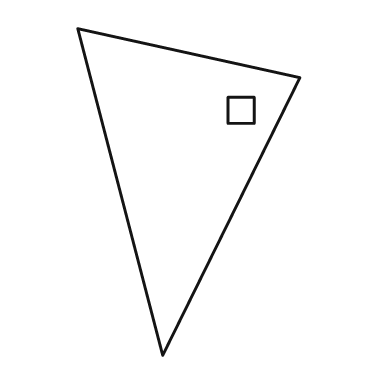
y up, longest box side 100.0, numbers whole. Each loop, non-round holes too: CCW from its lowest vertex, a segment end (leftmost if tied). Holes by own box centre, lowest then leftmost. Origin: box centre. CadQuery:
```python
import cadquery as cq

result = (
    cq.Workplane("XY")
    .moveTo(-8.0, -50.0)
    .lineTo(34.0, 35.0)
    .lineTo(-34.0, 50.0)
    .close()
    .moveTo(12.0, 21.0)
    .lineTo(20.0, 21.0)
    .lineTo(20.0, 29.0)
    .lineTo(12.0, 29.0)
    .close()
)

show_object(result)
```